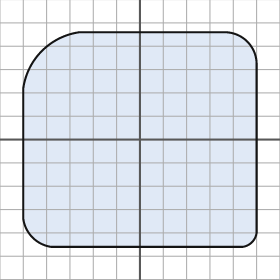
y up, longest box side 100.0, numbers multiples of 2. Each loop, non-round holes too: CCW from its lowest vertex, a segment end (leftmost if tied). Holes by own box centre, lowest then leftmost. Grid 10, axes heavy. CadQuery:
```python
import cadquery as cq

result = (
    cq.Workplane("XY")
    .moveTo(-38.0, -46.0)
    .lineTo(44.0, -46.0)
    .threePointArc((48.0, -44.0), (50.0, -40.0))
    .lineTo(50.0, 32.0)
    .threePointArc((46.0, 42.0), (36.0, 46.0))
    .lineTo(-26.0, 46.0)
    .threePointArc((-42.0, 38.0), (-50.0, 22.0))
    .lineTo(-50.0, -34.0)
    .threePointArc((-46.0, -42.0), (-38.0, -46.0))
    .close()
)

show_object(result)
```